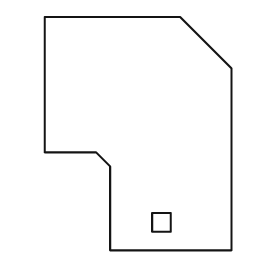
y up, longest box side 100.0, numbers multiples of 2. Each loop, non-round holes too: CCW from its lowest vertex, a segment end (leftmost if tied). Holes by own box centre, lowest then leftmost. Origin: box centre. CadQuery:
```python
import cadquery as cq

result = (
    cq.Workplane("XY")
    .moveTo(-12.0, -50.0)
    .lineTo(40.0, -50.0)
    .lineTo(40.0, 28.0)
    .lineTo(18.0, 50.0)
    .lineTo(-40.0, 50.0)
    .lineTo(-40.0, -8.0)
    .lineTo(-18.0, -8.0)
    .lineTo(-12.0, -14.0)
    .close()
    .moveTo(6.0, -42.0)
    .lineTo(14.0, -42.0)
    .lineTo(14.0, -34.0)
    .lineTo(6.0, -34.0)
    .close()
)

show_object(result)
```